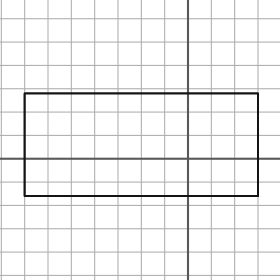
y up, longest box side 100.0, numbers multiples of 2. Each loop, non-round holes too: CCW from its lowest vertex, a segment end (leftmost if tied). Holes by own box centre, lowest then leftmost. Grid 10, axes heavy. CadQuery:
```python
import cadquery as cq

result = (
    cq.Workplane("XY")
    .moveTo(-70.0, -16.0)
    .lineTo(30.0, -16.0)
    .lineTo(30.0, 28.0)
    .lineTo(-70.0, 28.0)
    .close()
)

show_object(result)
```